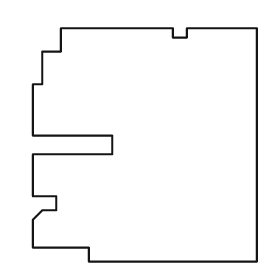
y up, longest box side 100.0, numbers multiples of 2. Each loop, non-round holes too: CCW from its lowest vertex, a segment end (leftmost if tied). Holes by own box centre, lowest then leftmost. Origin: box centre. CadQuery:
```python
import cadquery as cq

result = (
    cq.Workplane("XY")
    .moveTo(-24.0, -50.0)
    .lineTo(48.0, -50.0)
    .lineTo(48.0, 50.0)
    .lineTo(18.0, 50.0)
    .lineTo(18.0, 46.0)
    .lineTo(12.0, 46.0)
    .lineTo(12.0, 50.0)
    .lineTo(-36.0, 50.0)
    .lineTo(-36.0, 40.0)
    .lineTo(-44.0, 40.0)
    .lineTo(-44.0, 26.0)
    .lineTo(-48.0, 26.0)
    .lineTo(-48.0, 4.0)
    .lineTo(-14.0, 4.0)
    .lineTo(-14.0, -4.0)
    .lineTo(-48.0, -4.0)
    .lineTo(-48.0, -22.0)
    .lineTo(-38.0, -22.0)
    .lineTo(-38.0, -28.0)
    .lineTo(-44.0, -28.0)
    .lineTo(-48.0, -32.0)
    .lineTo(-48.0, -44.0)
    .lineTo(-24.0, -44.0)
    .close()
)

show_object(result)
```